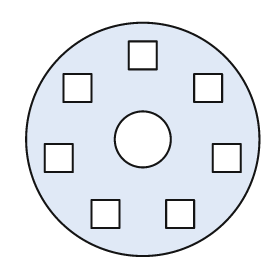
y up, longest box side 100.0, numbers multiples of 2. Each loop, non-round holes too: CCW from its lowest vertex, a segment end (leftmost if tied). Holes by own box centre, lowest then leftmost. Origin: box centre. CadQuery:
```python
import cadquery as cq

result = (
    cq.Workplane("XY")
    .moveTo(0.0, 0.0)
    .circle(50.0)
    .moveTo(-22.0, -38.0)
    .lineTo(-10.0, -38.0)
    .lineTo(-10.0, -26.0)
    .lineTo(-22.0, -26.0)
    .close()
    .moveTo(10.0, -38.0)
    .lineTo(22.0, -38.0)
    .lineTo(22.0, -26.0)
    .lineTo(10.0, -26.0)
    .close()
    .moveTo(-42.0, -14.0)
    .lineTo(-30.0, -14.0)
    .lineTo(-30.0, -2.0)
    .lineTo(-42.0, -2.0)
    .close()
    .moveTo(30.0, -14.0)
    .lineTo(42.0, -14.0)
    .lineTo(42.0, -2.0)
    .lineTo(30.0, -2.0)
    .close()
    .moveTo(0.0, 0.0)
    .circle(12.0)
    .moveTo(-34.0, 16.0)
    .lineTo(-22.0, 16.0)
    .lineTo(-22.0, 28.0)
    .lineTo(-34.0, 28.0)
    .close()
    .moveTo(22.0, 16.0)
    .lineTo(34.0, 16.0)
    .lineTo(34.0, 28.0)
    .lineTo(22.0, 28.0)
    .close()
    .moveTo(-6.0, 30.0)
    .lineTo(6.0, 30.0)
    .lineTo(6.0, 42.0)
    .lineTo(-6.0, 42.0)
    .close()
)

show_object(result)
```